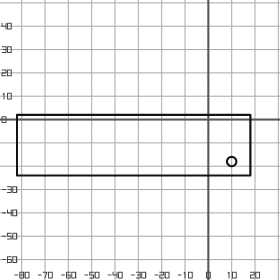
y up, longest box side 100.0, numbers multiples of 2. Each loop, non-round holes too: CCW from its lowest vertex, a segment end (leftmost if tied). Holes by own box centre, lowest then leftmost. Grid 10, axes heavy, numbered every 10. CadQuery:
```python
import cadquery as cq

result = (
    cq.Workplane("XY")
    .moveTo(-82.0, -24.0)
    .lineTo(18.0, -24.0)
    .lineTo(18.0, 2.0)
    .lineTo(-82.0, 2.0)
    .close()
    .moveTo(10.0, -18.0)
    .circle(2.0)
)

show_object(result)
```